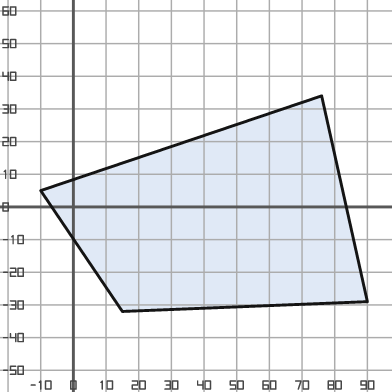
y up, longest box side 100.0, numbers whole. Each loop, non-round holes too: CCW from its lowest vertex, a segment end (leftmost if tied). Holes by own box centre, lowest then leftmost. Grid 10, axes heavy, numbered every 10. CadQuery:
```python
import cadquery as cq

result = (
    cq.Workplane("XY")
    .moveTo(15.0, -32.0)
    .lineTo(90.0, -29.0)
    .lineTo(76.0, 34.0)
    .lineTo(-10.0, 5.0)
    .close()
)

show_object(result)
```